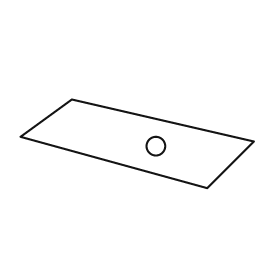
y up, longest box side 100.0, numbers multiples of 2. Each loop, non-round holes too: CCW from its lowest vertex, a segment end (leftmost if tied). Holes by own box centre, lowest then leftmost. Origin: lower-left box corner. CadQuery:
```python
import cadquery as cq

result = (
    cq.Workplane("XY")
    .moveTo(80.0, 0.0)
    .lineTo(100.0, 20.0)
    .lineTo(22.0, 38.0)
    .lineTo(0.0, 22.0)
    .close()
    .moveTo(58.0, 18.0)
    .circle(4.0)
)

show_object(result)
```